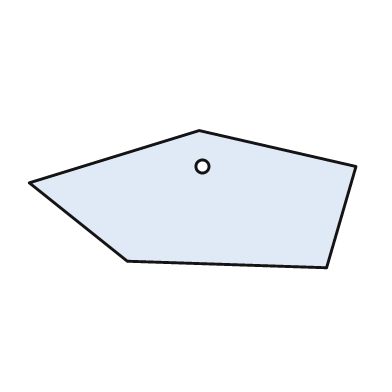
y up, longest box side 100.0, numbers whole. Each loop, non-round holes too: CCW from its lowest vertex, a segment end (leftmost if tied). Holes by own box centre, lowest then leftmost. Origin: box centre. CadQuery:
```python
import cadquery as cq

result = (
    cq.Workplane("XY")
    .moveTo(41.0, -21.0)
    .lineTo(50.0, 10.0)
    .lineTo(2.0, 21.0)
    .lineTo(-50.0, 5.0)
    .lineTo(-20.0, -19.0)
    .close()
    .moveTo(3.0, 10.0)
    .circle(2.0)
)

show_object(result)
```